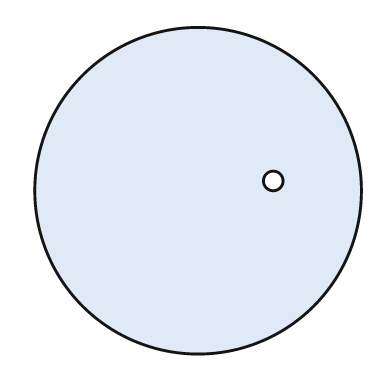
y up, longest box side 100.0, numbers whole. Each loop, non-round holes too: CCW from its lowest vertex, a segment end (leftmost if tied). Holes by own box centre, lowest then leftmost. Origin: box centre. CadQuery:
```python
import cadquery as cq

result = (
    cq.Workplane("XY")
    .moveTo(0.0, 0.0)
    .circle(50.0)
    .moveTo(23.0, 3.0)
    .circle(3.0)
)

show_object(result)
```